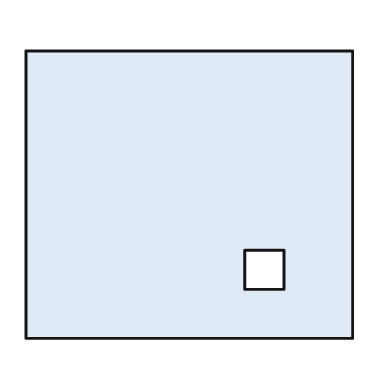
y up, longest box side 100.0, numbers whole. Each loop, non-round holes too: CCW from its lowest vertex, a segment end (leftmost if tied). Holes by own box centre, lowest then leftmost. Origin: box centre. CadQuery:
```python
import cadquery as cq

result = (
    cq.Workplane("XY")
    .moveTo(-50.0, -44.0)
    .lineTo(50.0, -44.0)
    .lineTo(50.0, 44.0)
    .lineTo(-50.0, 44.0)
    .close()
    .moveTo(17.0, -29.0)
    .lineTo(29.0, -29.0)
    .lineTo(29.0, -17.0)
    .lineTo(17.0, -17.0)
    .close()
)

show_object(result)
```